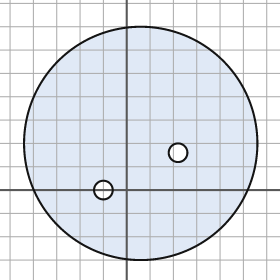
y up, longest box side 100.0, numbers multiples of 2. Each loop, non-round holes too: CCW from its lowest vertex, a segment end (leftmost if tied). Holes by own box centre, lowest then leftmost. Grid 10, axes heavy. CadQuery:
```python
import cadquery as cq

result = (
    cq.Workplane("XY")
    .moveTo(6.0, 20.0)
    .circle(50.0)
    .moveTo(-10.0, 0.0)
    .circle(4.0)
    .moveTo(22.0, 16.0)
    .circle(4.0)
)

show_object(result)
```